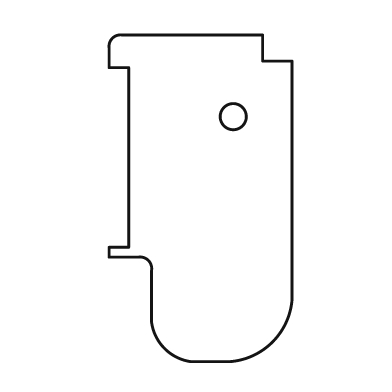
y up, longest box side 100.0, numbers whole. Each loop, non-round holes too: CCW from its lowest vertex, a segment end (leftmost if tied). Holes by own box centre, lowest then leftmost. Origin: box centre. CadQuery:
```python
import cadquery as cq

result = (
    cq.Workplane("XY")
    .moveTo(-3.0, -50.0)
    .lineTo(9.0, -50.0)
    .threePointArc((22.0, -44.0), (28.0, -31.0))
    .lineTo(28.0, 42.0)
    .lineTo(19.0, 42.0)
    .lineTo(19.0, 50.0)
    .lineTo(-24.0, 50.0)
    .threePointArc((-27.0, 49.0), (-28.0, 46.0))
    .lineTo(-28.0, 40.0)
    .lineTo(-22.0, 40.0)
    .lineTo(-22.0, -15.0)
    .lineTo(-28.0, -15.0)
    .lineTo(-28.0, -18.0)
    .lineTo(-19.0, -18.0)
    .threePointArc((-16.0, -19.0), (-15.0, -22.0))
    .lineTo(-15.0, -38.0)
    .threePointArc((-11.0, -46.0), (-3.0, -50.0))
    .close()
    .moveTo(10.0, 25.0)
    .circle(4.0)
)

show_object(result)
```